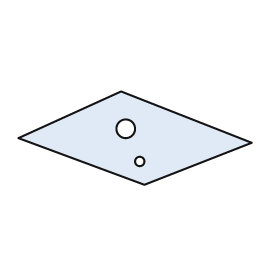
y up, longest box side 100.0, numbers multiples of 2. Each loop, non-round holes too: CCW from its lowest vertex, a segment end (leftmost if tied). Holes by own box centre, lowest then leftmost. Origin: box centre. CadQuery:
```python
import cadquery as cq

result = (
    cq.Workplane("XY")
    .moveTo(4.0, -20.0)
    .lineTo(50.0, -2.0)
    .lineTo(-6.0, 20.0)
    .lineTo(-50.0, 0.0)
    .close()
    .moveTo(2.0, -10.0)
    .circle(2.0)
    .moveTo(-4.0, 4.0)
    .circle(4.0)
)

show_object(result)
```